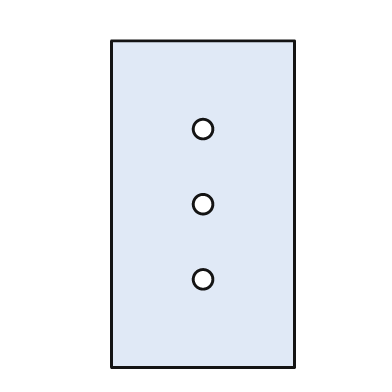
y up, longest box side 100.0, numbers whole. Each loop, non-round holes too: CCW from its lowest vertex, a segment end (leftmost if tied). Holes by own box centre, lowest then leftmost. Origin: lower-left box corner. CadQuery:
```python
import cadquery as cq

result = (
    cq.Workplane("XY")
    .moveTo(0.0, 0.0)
    .lineTo(56.0, 0.0)
    .lineTo(56.0, 100.0)
    .lineTo(0.0, 100.0)
    .close()
    .moveTo(28.0, 27.0)
    .circle(3.0)
    .moveTo(28.0, 50.0)
    .circle(3.0)
    .moveTo(28.0, 73.0)
    .circle(3.0)
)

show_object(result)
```